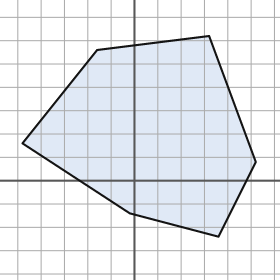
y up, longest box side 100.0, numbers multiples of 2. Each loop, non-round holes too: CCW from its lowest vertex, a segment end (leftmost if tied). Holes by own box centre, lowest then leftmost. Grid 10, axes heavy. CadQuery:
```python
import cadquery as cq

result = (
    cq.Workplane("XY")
    .moveTo(36.0, -24.0)
    .lineTo(52.0, 8.0)
    .lineTo(32.0, 62.0)
    .lineTo(-16.0, 56.0)
    .lineTo(-48.0, 16.0)
    .lineTo(-2.0, -14.0)
    .close()
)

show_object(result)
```